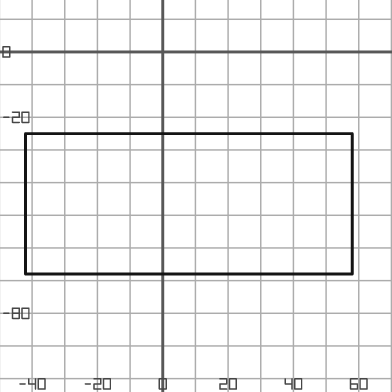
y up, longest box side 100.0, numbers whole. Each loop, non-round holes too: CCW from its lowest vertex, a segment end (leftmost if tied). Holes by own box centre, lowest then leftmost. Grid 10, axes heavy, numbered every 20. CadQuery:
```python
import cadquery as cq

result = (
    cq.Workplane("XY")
    .moveTo(-42.0, -68.0)
    .lineTo(58.0, -68.0)
    .lineTo(58.0, -25.0)
    .lineTo(-42.0, -25.0)
    .close()
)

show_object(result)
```